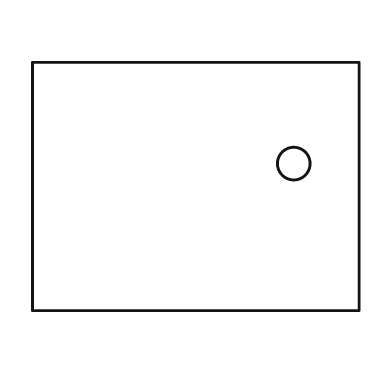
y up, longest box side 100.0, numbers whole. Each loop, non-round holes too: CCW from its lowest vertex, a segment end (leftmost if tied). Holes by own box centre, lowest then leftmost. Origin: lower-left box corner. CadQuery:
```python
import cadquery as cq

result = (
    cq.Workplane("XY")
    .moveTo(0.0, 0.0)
    .lineTo(100.0, 0.0)
    .lineTo(100.0, 76.0)
    .lineTo(0.0, 76.0)
    .close()
    .moveTo(80.0, 45.0)
    .circle(5.0)
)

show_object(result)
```